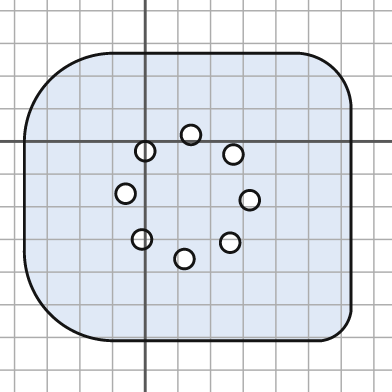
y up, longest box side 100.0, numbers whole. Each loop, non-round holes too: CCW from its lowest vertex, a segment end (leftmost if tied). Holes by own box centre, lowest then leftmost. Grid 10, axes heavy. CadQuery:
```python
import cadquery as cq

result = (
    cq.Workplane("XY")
    .moveTo(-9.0, -61.0)
    .lineTo(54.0, -61.0)
    .threePointArc((60.0, -58.0), (63.0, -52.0))
    .lineTo(63.0, 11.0)
    .threePointArc((58.0, 22.0), (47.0, 27.0))
    .lineTo(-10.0, 27.0)
    .threePointArc((-29.0, 19.0), (-37.0, 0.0))
    .lineTo(-37.0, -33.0)
    .threePointArc((-29.0, -53.0), (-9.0, -61.0))
    .close()
    .moveTo(12.0, -36.0)
    .circle(3.0)
    .moveTo(26.0, -31.0)
    .circle(3.0)
    .moveTo(-1.0, -30.0)
    .circle(3.0)
    .moveTo(32.0, -18.0)
    .circle(3.0)
    .moveTo(-6.0, -16.0)
    .circle(3.0)
    .moveTo(27.0, -4.0)
    .circle(3.0)
    .moveTo(0.0, -3.0)
    .circle(3.0)
    .moveTo(14.0, 2.0)
    .circle(3.0)
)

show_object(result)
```